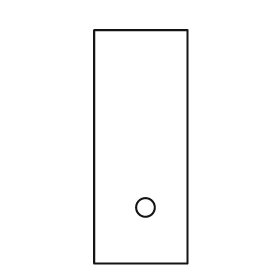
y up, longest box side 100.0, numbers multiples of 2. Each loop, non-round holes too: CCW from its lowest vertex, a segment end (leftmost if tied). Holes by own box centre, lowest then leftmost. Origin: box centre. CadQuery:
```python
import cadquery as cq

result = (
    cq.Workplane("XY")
    .moveTo(-20.0, -50.0)
    .lineTo(20.0, -50.0)
    .lineTo(20.0, 50.0)
    .lineTo(-20.0, 50.0)
    .close()
    .moveTo(2.0, -26.0)
    .circle(4.0)
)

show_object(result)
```